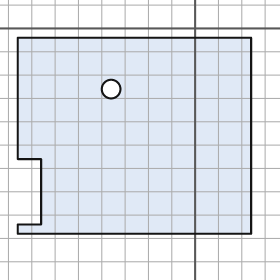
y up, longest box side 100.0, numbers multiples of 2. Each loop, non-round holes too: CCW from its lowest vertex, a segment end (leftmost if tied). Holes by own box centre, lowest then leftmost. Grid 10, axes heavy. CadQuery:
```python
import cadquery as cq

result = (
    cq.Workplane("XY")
    .moveTo(-76.0, -88.0)
    .lineTo(24.0, -88.0)
    .lineTo(24.0, -4.0)
    .lineTo(-76.0, -4.0)
    .lineTo(-76.0, -56.0)
    .lineTo(-66.0, -56.0)
    .lineTo(-66.0, -84.0)
    .lineTo(-76.0, -84.0)
    .close()
    .moveTo(-36.0, -26.0)
    .circle(4.0)
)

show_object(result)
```